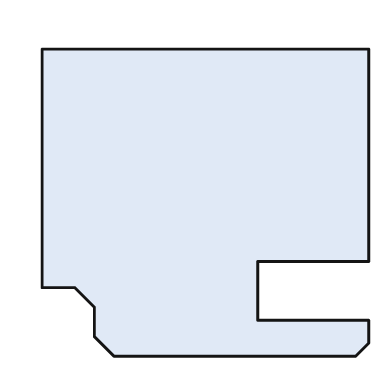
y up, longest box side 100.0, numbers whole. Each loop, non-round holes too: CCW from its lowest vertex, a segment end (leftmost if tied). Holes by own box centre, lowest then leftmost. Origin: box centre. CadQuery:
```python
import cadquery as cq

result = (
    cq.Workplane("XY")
    .moveTo(-28.0, -47.0)
    .lineTo(46.0, -47.0)
    .lineTo(50.0, -43.0)
    .lineTo(50.0, -36.0)
    .lineTo(16.0, -36.0)
    .lineTo(16.0, -18.0)
    .lineTo(50.0, -18.0)
    .lineTo(50.0, 47.0)
    .lineTo(-50.0, 47.0)
    .lineTo(-50.0, -26.0)
    .lineTo(-40.0, -26.0)
    .lineTo(-34.0, -32.0)
    .lineTo(-34.0, -41.0)
    .close()
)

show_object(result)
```